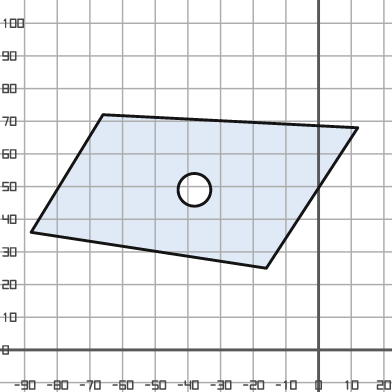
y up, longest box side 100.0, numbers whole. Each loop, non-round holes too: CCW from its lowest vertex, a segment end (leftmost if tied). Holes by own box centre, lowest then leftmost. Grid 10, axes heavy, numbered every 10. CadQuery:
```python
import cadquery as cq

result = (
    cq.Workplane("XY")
    .moveTo(-16.0, 25.0)
    .lineTo(12.0, 68.0)
    .lineTo(-66.0, 72.0)
    .lineTo(-88.0, 36.0)
    .close()
    .moveTo(-38.0, 49.0)
    .circle(5.0)
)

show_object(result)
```